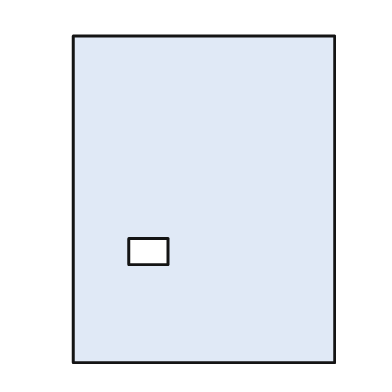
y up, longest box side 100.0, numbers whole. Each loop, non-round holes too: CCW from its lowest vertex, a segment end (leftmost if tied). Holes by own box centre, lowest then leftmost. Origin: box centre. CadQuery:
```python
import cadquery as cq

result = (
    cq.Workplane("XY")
    .moveTo(-40.0, -50.0)
    .lineTo(40.0, -50.0)
    .lineTo(40.0, 50.0)
    .lineTo(-40.0, 50.0)
    .close()
    .moveTo(-23.0, -20.0)
    .lineTo(-11.0, -20.0)
    .lineTo(-11.0, -12.0)
    .lineTo(-23.0, -12.0)
    .close()
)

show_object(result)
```